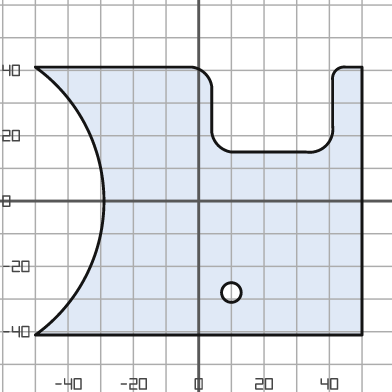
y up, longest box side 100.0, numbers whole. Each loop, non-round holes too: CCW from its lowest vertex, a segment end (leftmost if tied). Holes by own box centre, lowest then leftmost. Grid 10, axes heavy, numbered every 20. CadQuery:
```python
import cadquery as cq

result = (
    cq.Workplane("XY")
    .moveTo(-50.0, -41.0)
    .lineTo(50.0, -41.0)
    .lineTo(50.0, 41.0)
    .lineTo(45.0, 41.0)
    .threePointArc((42.0, 40.0), (41.0, 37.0))
    .lineTo(41.0, 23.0)
    .threePointArc((39.0, 17.0), (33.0, 15.0))
    .lineTo(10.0, 15.0)
    .threePointArc((6.0, 17.0), (4.0, 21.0))
    .lineTo(4.0, 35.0)
    .threePointArc((2.0, 39.0), (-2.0, 41.0))
    .lineTo(-50.0, 41.0)
    .threePointArc((-29.0, 0.0), (-50.0, -41.0))
    .close()
    .moveTo(10.0, -28.0)
    .circle(3.0)
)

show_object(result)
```